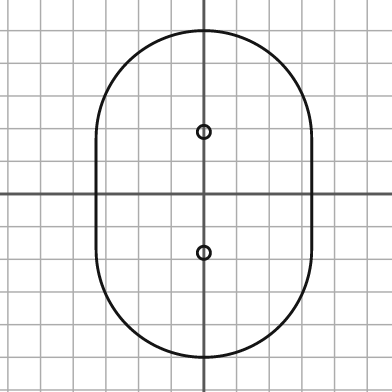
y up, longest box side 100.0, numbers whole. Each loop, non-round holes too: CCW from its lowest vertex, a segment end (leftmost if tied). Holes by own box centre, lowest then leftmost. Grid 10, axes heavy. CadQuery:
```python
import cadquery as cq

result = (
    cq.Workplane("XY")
    .moveTo(-33.0, -17.0)
    .threePointArc((0.0, -50.0), (33.0, -17.0))
    .lineTo(33.0, 17.0)
    .threePointArc((0.0, 50.0), (-33.0, 17.0))
    .close()
    .moveTo(0.0, -18.0)
    .circle(2.0)
    .moveTo(0.0, 19.0)
    .circle(2.0)
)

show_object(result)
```